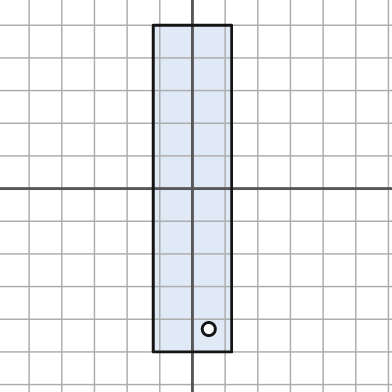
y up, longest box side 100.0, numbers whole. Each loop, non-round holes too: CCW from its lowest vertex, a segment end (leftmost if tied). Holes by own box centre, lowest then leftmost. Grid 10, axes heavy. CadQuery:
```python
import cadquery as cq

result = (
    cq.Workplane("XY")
    .moveTo(-12.0, -50.0)
    .lineTo(12.0, -50.0)
    .lineTo(12.0, 50.0)
    .lineTo(-12.0, 50.0)
    .close()
    .moveTo(5.0, -43.0)
    .circle(2.0)
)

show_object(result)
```